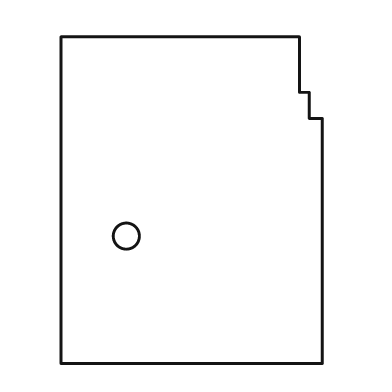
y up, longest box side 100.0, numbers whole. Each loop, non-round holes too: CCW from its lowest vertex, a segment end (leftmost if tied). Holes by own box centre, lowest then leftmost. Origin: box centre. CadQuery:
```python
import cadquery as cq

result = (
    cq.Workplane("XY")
    .moveTo(-40.0, -50.0)
    .lineTo(40.0, -50.0)
    .lineTo(40.0, 25.0)
    .lineTo(36.0, 25.0)
    .lineTo(36.0, 33.0)
    .lineTo(33.0, 33.0)
    .lineTo(33.0, 50.0)
    .lineTo(-40.0, 50.0)
    .close()
    .moveTo(-20.0, -11.0)
    .circle(4.0)
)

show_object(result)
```